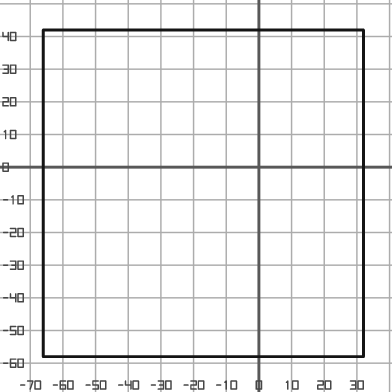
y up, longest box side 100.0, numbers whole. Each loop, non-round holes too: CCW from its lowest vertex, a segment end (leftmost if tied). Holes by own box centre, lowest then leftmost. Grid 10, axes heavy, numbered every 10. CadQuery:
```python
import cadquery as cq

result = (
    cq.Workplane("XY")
    .moveTo(-66.0, -58.0)
    .lineTo(32.0, -58.0)
    .lineTo(32.0, 42.0)
    .lineTo(-66.0, 42.0)
    .close()
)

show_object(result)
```